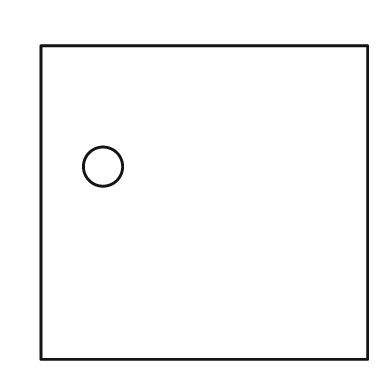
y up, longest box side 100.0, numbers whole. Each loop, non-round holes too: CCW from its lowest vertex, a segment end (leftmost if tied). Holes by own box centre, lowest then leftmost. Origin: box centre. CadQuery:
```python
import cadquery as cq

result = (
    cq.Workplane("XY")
    .moveTo(-50.0, -48.0)
    .lineTo(50.0, -48.0)
    .lineTo(50.0, 48.0)
    .lineTo(-50.0, 48.0)
    .close()
    .moveTo(-31.0, 11.0)
    .circle(6.0)
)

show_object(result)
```